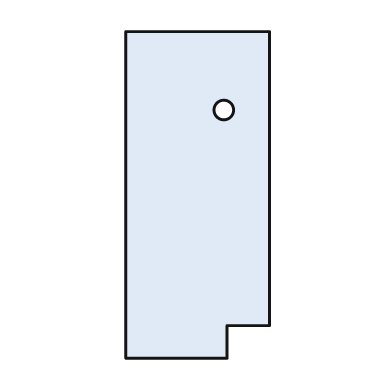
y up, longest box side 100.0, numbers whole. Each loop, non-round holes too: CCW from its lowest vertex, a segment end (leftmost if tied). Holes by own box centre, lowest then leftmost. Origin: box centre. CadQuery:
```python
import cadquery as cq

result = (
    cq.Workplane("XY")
    .moveTo(-22.0, -50.0)
    .lineTo(9.0, -50.0)
    .lineTo(9.0, -40.0)
    .lineTo(22.0, -40.0)
    .lineTo(22.0, 50.0)
    .lineTo(-22.0, 50.0)
    .close()
    .moveTo(8.0, 26.0)
    .circle(3.0)
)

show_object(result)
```